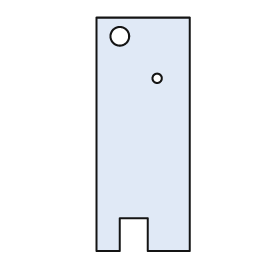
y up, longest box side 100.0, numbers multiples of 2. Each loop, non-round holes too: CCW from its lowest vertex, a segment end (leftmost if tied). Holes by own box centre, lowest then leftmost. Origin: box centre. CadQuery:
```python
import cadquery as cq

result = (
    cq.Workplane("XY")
    .moveTo(-20.0, -50.0)
    .lineTo(-10.0, -50.0)
    .lineTo(-10.0, -36.0)
    .lineTo(2.0, -36.0)
    .lineTo(2.0, -50.0)
    .lineTo(20.0, -50.0)
    .lineTo(20.0, 50.0)
    .lineTo(-20.0, 50.0)
    .close()
    .moveTo(6.0, 24.0)
    .circle(2.0)
    .moveTo(-10.0, 42.0)
    .circle(4.0)
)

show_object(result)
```